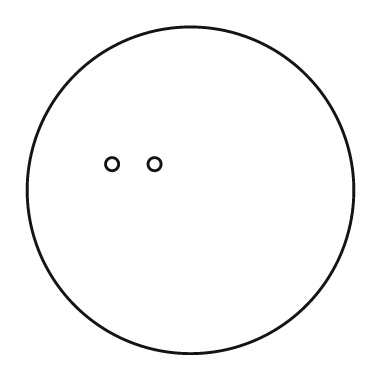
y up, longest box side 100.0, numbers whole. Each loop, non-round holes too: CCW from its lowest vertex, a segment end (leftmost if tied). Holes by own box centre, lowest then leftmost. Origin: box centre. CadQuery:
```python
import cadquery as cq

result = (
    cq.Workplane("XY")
    .moveTo(0.0, 0.0)
    .circle(50.0)
    .moveTo(-24.0, 8.0)
    .circle(2.0)
    .moveTo(-11.0, 8.0)
    .circle(2.0)
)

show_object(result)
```